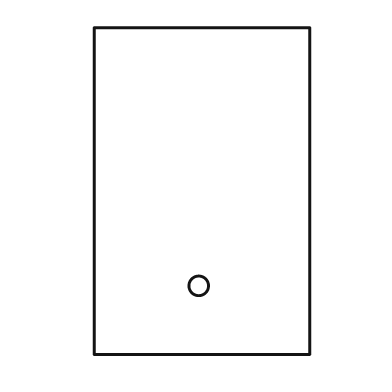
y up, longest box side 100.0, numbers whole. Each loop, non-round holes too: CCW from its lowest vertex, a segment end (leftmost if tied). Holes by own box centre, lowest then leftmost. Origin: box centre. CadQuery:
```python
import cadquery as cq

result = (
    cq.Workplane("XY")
    .moveTo(-33.0, -50.0)
    .lineTo(33.0, -50.0)
    .lineTo(33.0, 50.0)
    .lineTo(-33.0, 50.0)
    .close()
    .moveTo(-1.0, -29.0)
    .circle(3.0)
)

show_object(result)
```